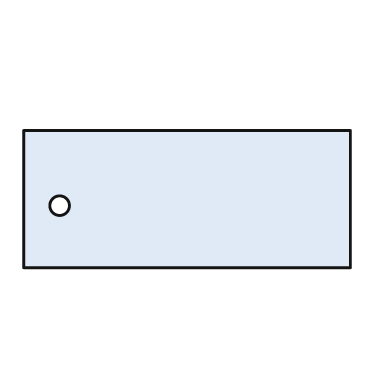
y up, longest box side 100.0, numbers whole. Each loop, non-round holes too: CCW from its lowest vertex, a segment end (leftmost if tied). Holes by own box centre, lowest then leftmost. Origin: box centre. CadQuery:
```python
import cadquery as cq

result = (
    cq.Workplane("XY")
    .moveTo(-50.0, -21.0)
    .lineTo(50.0, -21.0)
    .lineTo(50.0, 21.0)
    .lineTo(-50.0, 21.0)
    .close()
    .moveTo(-39.0, -2.0)
    .circle(3.0)
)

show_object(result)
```